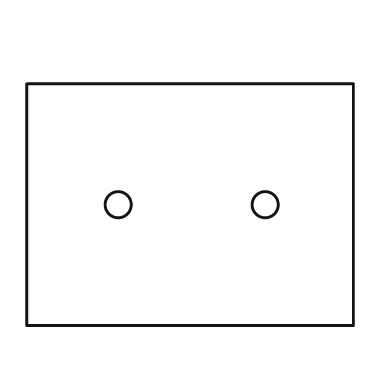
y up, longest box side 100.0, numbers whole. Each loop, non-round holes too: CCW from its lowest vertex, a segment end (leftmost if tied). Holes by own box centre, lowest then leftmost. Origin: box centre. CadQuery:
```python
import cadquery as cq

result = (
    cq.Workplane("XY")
    .moveTo(-50.0, -37.0)
    .lineTo(50.0, -37.0)
    .lineTo(50.0, 37.0)
    .lineTo(-50.0, 37.0)
    .close()
    .moveTo(-22.0, 0.0)
    .circle(4.0)
    .moveTo(23.0, 0.0)
    .circle(4.0)
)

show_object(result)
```